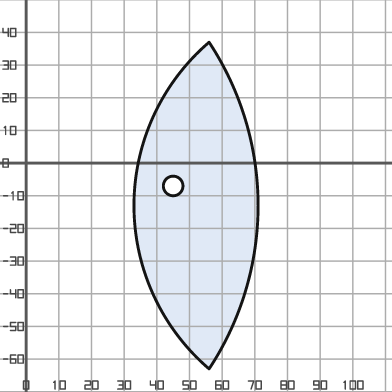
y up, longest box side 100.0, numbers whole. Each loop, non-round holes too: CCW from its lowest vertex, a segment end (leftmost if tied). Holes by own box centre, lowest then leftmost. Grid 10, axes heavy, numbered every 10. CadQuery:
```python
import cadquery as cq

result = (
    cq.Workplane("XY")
    .moveTo(56.0, -63.0)
    .threePointArc((71.0, -13.0), (56.0, 37.0))
    .threePointArc((33.0, -13.0), (56.0, -63.0))
    .close()
    .moveTo(45.0, -7.0)
    .circle(3.0)
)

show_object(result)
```